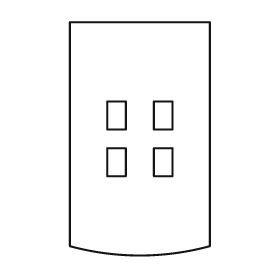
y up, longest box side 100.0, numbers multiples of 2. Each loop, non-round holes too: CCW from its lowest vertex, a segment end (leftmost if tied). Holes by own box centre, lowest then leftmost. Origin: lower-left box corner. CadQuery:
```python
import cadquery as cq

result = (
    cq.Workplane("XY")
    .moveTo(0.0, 4.0)
    .threePointArc((30.0, 0.0), (60.0, 4.0))
    .lineTo(60.0, 100.0)
    .lineTo(0.0, 100.0)
    .close()
    .moveTo(16.0, 34.0)
    .lineTo(24.0, 34.0)
    .lineTo(24.0, 46.0)
    .lineTo(16.0, 46.0)
    .close()
    .moveTo(36.0, 34.0)
    .lineTo(44.0, 34.0)
    .lineTo(44.0, 46.0)
    .lineTo(36.0, 46.0)
    .close()
    .moveTo(16.0, 54.0)
    .lineTo(24.0, 54.0)
    .lineTo(24.0, 66.0)
    .lineTo(16.0, 66.0)
    .close()
    .moveTo(36.0, 54.0)
    .lineTo(44.0, 54.0)
    .lineTo(44.0, 66.0)
    .lineTo(36.0, 66.0)
    .close()
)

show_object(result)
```